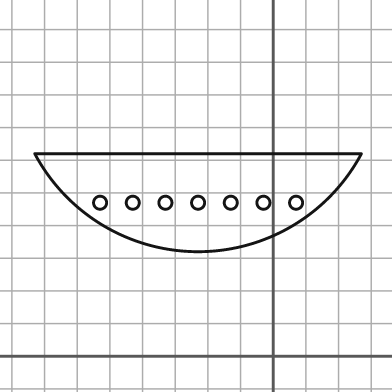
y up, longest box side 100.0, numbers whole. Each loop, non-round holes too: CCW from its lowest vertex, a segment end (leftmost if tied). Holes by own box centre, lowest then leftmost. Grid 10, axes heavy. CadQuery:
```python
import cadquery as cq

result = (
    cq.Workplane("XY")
    .moveTo(-73.0, 62.0)
    .threePointArc((-23.0, 32.0), (27.0, 62.0))
    .close()
    .moveTo(-53.0, 47.0)
    .circle(2.0)
    .moveTo(-43.0, 47.0)
    .circle(2.0)
    .moveTo(-33.0, 47.0)
    .circle(2.0)
    .moveTo(-23.0, 47.0)
    .circle(2.0)
    .moveTo(-13.0, 47.0)
    .circle(2.0)
    .moveTo(-3.0, 47.0)
    .circle(2.0)
    .moveTo(7.0, 47.0)
    .circle(2.0)
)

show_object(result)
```